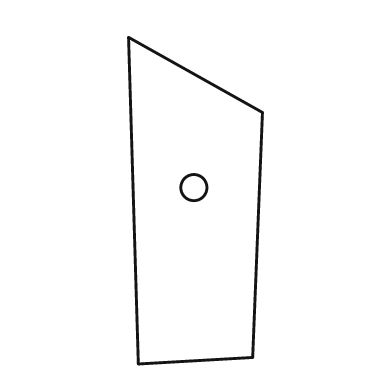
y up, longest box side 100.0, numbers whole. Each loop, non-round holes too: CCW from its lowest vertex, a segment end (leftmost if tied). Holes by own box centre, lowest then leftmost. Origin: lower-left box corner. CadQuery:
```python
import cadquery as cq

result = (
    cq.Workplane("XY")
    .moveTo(3.0, 0.0)
    .lineTo(38.0, 2.0)
    .lineTo(41.0, 77.0)
    .lineTo(0.0, 100.0)
    .close()
    .moveTo(20.0, 54.0)
    .circle(4.0)
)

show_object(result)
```